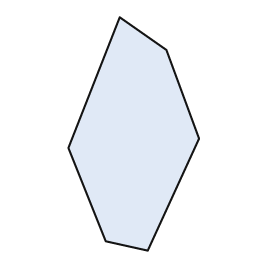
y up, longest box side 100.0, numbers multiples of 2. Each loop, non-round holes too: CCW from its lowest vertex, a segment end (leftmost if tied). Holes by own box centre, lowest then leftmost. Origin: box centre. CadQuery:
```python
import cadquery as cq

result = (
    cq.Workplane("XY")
    .moveTo(6.0, -50.0)
    .lineTo(28.0, -2.0)
    .lineTo(14.0, 36.0)
    .lineTo(-6.0, 50.0)
    .lineTo(-28.0, -6.0)
    .lineTo(-12.0, -46.0)
    .close()
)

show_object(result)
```